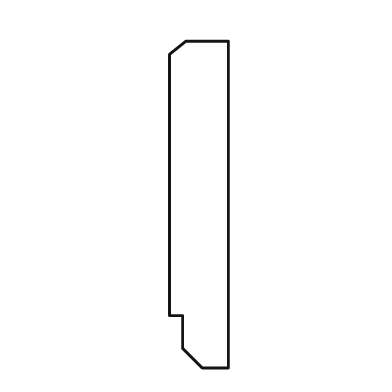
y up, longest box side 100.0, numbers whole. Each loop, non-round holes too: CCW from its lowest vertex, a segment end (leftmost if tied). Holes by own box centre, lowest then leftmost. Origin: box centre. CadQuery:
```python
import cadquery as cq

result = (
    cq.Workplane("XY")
    .moveTo(1.0, -50.0)
    .lineTo(9.0, -50.0)
    .lineTo(9.0, 50.0)
    .lineTo(-4.0, 50.0)
    .lineTo(-9.0, 46.0)
    .lineTo(-9.0, -34.0)
    .lineTo(-5.0, -34.0)
    .lineTo(-5.0, -44.0)
    .close()
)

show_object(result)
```